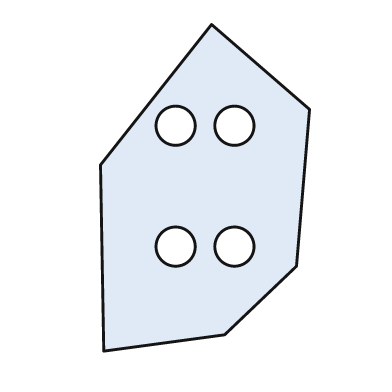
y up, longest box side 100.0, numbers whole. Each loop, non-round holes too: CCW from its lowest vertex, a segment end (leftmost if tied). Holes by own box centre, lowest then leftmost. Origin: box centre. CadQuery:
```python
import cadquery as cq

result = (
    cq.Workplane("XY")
    .moveTo(-31.0, -50.0)
    .lineTo(6.0, -45.0)
    .lineTo(28.0, -24.0)
    .lineTo(32.0, 24.0)
    .lineTo(2.0, 50.0)
    .lineTo(-32.0, 7.0)
    .close()
    .moveTo(-9.0, -18.0)
    .circle(6.0)
    .moveTo(9.0, -18.0)
    .circle(6.0)
    .moveTo(-9.0, 19.0)
    .circle(6.0)
    .moveTo(9.0, 19.0)
    .circle(6.0)
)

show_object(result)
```